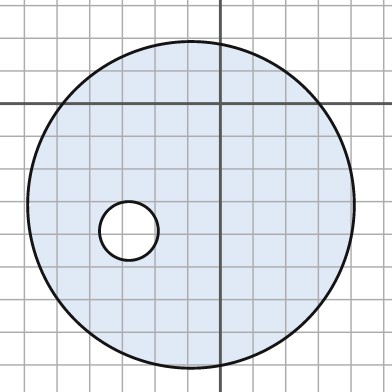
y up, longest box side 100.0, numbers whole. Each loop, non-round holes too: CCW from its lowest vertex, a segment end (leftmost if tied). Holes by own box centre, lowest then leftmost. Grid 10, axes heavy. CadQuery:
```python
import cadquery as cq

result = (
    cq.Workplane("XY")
    .moveTo(-9.0, -31.0)
    .circle(50.0)
    .moveTo(-28.0, -39.0)
    .circle(9.0)
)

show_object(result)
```